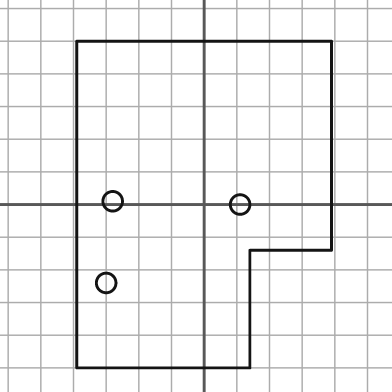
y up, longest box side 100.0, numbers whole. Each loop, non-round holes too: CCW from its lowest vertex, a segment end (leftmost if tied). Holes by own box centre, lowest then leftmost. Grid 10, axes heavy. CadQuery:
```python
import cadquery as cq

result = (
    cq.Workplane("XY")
    .moveTo(-39.0, -50.0)
    .lineTo(14.0, -50.0)
    .lineTo(14.0, -14.0)
    .lineTo(39.0, -14.0)
    .lineTo(39.0, 50.0)
    .lineTo(-39.0, 50.0)
    .close()
    .moveTo(-30.0, -24.0)
    .circle(3.0)
    .moveTo(11.0, 0.0)
    .circle(3.0)
    .moveTo(-28.0, 1.0)
    .circle(3.0)
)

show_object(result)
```